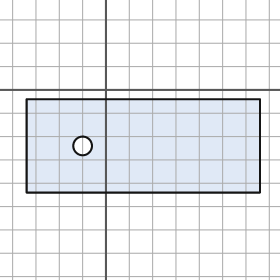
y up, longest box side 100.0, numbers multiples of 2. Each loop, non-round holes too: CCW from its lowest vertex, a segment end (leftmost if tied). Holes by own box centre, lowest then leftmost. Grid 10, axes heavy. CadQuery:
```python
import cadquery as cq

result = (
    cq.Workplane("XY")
    .moveTo(-34.0, -44.0)
    .lineTo(66.0, -44.0)
    .lineTo(66.0, -4.0)
    .lineTo(-34.0, -4.0)
    .close()
    .moveTo(-10.0, -24.0)
    .circle(4.0)
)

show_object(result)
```